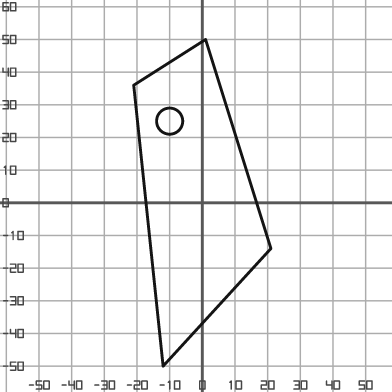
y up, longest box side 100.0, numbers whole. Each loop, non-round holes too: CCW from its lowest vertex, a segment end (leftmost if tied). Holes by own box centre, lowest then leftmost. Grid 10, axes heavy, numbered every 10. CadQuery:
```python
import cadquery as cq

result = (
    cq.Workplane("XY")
    .moveTo(-12.0, -50.0)
    .lineTo(21.0, -14.0)
    .lineTo(1.0, 50.0)
    .lineTo(-21.0, 36.0)
    .close()
    .moveTo(-10.0, 25.0)
    .circle(4.0)
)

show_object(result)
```